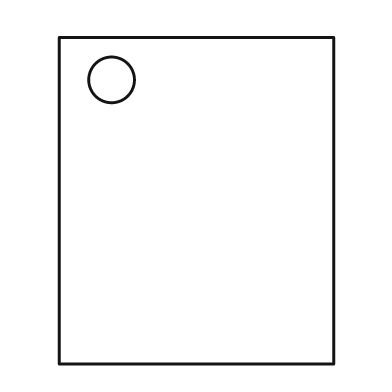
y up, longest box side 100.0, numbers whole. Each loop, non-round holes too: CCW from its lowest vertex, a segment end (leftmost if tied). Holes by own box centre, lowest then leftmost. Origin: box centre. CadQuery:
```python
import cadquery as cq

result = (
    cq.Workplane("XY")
    .moveTo(-42.0, -50.0)
    .lineTo(42.0, -50.0)
    .lineTo(42.0, 50.0)
    .lineTo(-42.0, 50.0)
    .close()
    .moveTo(-26.0, 37.0)
    .circle(7.0)
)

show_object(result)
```